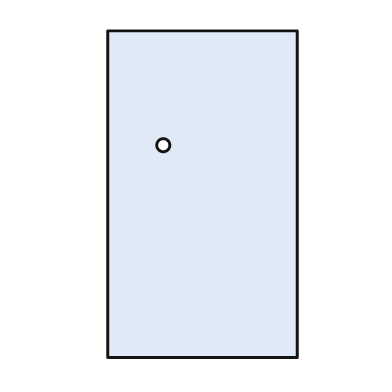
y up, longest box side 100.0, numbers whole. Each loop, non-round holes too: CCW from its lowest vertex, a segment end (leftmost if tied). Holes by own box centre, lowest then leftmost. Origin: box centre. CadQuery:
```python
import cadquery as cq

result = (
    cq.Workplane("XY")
    .moveTo(-29.0, -50.0)
    .lineTo(29.0, -50.0)
    .lineTo(29.0, 50.0)
    .lineTo(-29.0, 50.0)
    .close()
    .moveTo(-12.0, 15.0)
    .circle(2.0)
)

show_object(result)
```